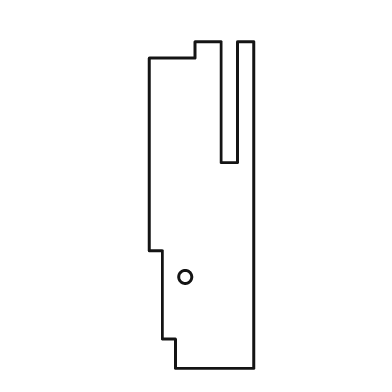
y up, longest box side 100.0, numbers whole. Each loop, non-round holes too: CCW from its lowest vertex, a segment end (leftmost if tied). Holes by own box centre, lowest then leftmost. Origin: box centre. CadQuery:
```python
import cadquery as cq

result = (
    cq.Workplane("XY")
    .moveTo(-8.0, -50.0)
    .lineTo(16.0, -50.0)
    .lineTo(16.0, 50.0)
    .lineTo(11.0, 50.0)
    .lineTo(11.0, 13.0)
    .lineTo(6.0, 13.0)
    .lineTo(6.0, 50.0)
    .lineTo(-2.0, 50.0)
    .lineTo(-2.0, 45.0)
    .lineTo(-16.0, 45.0)
    .lineTo(-16.0, -14.0)
    .lineTo(-12.0, -14.0)
    .lineTo(-12.0, -41.0)
    .lineTo(-8.0, -41.0)
    .close()
    .moveTo(-5.0, -22.0)
    .circle(2.0)
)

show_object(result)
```